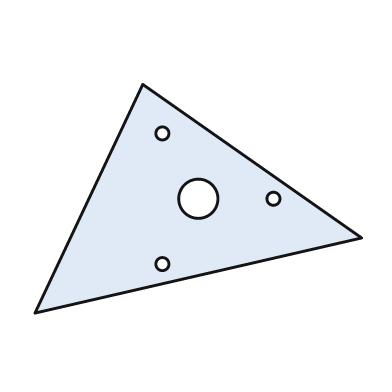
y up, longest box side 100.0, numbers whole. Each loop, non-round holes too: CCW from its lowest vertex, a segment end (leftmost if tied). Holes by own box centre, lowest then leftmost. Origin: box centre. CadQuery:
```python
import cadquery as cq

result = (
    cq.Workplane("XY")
    .moveTo(-50.0, -35.0)
    .lineTo(50.0, -12.0)
    .lineTo(-17.0, 35.0)
    .close()
    .moveTo(-11.0, -20.0)
    .circle(2.0)
    .moveTo(0.0, 0.0)
    .circle(6.0)
    .moveTo(23.0, 0.0)
    .circle(2.0)
    .moveTo(-11.0, 20.0)
    .circle(2.0)
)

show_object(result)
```